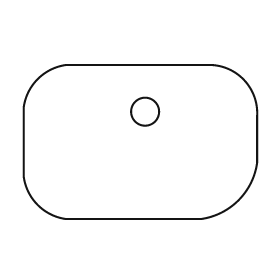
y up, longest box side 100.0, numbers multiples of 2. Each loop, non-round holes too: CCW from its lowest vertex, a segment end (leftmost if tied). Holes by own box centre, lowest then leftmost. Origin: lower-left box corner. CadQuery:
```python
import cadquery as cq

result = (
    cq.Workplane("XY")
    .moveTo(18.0, 0.0)
    .lineTo(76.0, 0.0)
    .threePointArc((92.0, 8.0), (100.0, 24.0))
    .lineTo(100.0, 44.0)
    .threePointArc((94.0, 60.0), (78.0, 66.0))
    .lineTo(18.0, 66.0)
    .threePointArc((6.0, 60.0), (0.0, 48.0))
    .lineTo(0.0, 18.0)
    .threePointArc((6.0, 6.0), (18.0, 0.0))
    .close()
    .moveTo(52.0, 46.0)
    .circle(6.0)
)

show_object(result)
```